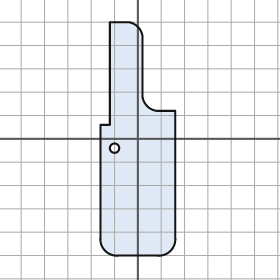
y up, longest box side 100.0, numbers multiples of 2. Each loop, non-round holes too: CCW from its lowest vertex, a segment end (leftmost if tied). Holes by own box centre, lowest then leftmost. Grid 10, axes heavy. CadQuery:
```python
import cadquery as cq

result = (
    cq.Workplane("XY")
    .moveTo(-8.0, -50.0)
    .lineTo(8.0, -50.0)
    .threePointArc((14.0, -48.0), (16.0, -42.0))
    .lineTo(16.0, 12.0)
    .lineTo(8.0, 12.0)
    .threePointArc((4.0, 14.0), (2.0, 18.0))
    .lineTo(2.0, 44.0)
    .threePointArc((0.0, 48.0), (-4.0, 50.0))
    .lineTo(-12.0, 50.0)
    .lineTo(-12.0, 6.0)
    .lineTo(-16.0, 6.0)
    .lineTo(-16.0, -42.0)
    .threePointArc((-14.0, -48.0), (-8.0, -50.0))
    .close()
    .moveTo(-10.0, -4.0)
    .circle(2.0)
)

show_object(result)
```